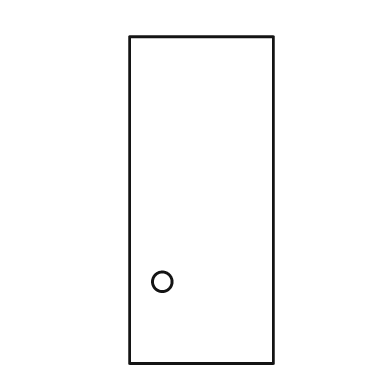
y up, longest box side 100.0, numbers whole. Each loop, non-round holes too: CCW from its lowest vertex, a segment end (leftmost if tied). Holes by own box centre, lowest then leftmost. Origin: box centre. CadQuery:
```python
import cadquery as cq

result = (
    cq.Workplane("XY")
    .moveTo(-22.0, -50.0)
    .lineTo(22.0, -50.0)
    .lineTo(22.0, 50.0)
    .lineTo(-22.0, 50.0)
    .close()
    .moveTo(-12.0, -25.0)
    .circle(3.0)
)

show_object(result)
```